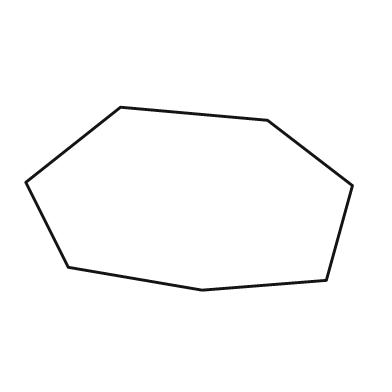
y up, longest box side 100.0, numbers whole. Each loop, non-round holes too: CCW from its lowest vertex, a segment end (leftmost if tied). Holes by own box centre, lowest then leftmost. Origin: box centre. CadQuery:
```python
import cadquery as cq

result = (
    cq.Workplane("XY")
    .moveTo(4.0, -28.0)
    .lineTo(42.0, -25.0)
    .lineTo(50.0, 4.0)
    .lineTo(24.0, 24.0)
    .lineTo(-21.0, 28.0)
    .lineTo(-50.0, 5.0)
    .lineTo(-37.0, -21.0)
    .close()
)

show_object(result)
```